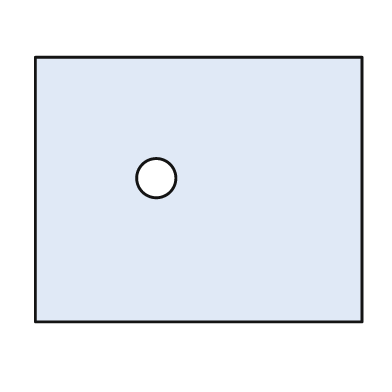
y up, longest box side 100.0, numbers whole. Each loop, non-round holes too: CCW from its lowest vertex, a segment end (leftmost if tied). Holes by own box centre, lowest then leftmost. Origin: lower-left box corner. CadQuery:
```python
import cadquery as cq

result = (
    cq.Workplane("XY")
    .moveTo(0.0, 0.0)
    .lineTo(100.0, 0.0)
    .lineTo(100.0, 81.0)
    .lineTo(0.0, 81.0)
    .close()
    .moveTo(37.0, 44.0)
    .circle(6.0)
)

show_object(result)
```